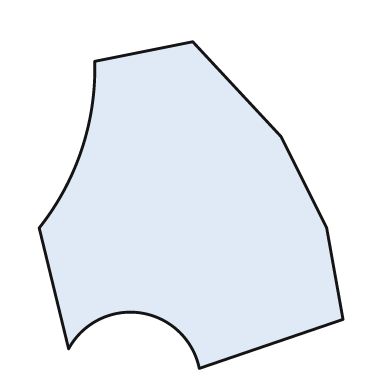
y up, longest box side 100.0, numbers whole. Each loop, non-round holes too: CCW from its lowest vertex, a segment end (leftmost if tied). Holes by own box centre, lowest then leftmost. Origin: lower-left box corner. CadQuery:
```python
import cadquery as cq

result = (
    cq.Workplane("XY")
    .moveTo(49.0, 0.0)
    .lineTo(93.0, 15.0)
    .lineTo(88.0, 43.0)
    .lineTo(74.0, 71.0)
    .lineTo(47.0, 100.0)
    .lineTo(17.0, 94.0)
    .threePointArc((13.0, 67.0), (0.0, 43.0))
    .lineTo(9.0, 6.0)
    .threePointArc((31.0, 17.0), (49.0, 0.0))
    .close()
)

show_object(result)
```